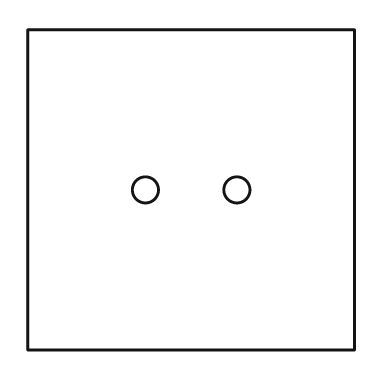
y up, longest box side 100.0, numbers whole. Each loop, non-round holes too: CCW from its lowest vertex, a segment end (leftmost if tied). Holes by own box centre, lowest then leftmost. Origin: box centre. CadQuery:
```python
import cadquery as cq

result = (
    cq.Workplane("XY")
    .moveTo(-50.0, -49.0)
    .lineTo(50.0, -49.0)
    .lineTo(50.0, 49.0)
    .lineTo(-50.0, 49.0)
    .close()
    .moveTo(-14.0, 0.0)
    .circle(4.0)
    .moveTo(14.0, 0.0)
    .circle(4.0)
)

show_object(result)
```